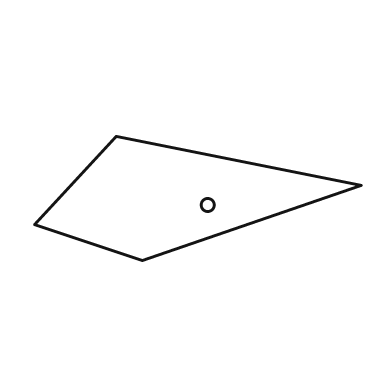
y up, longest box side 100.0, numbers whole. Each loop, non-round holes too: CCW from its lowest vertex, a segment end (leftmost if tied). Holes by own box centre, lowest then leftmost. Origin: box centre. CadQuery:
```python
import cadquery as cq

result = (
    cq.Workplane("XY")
    .moveTo(-17.0, -19.0)
    .lineTo(50.0, 4.0)
    .lineTo(-25.0, 19.0)
    .lineTo(-50.0, -8.0)
    .close()
    .moveTo(3.0, -2.0)
    .circle(2.0)
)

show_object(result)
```